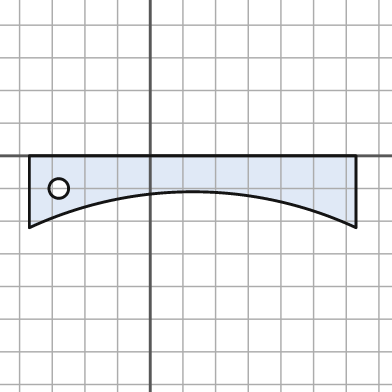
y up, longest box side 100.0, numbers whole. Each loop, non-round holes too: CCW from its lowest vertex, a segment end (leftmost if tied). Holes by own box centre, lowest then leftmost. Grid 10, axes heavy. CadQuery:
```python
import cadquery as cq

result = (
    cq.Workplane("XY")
    .moveTo(-37.0, -22.0)
    .threePointArc((13.0, -11.0), (63.0, -22.0))
    .lineTo(63.0, 0.0)
    .lineTo(-37.0, 0.0)
    .close()
    .moveTo(-28.0, -10.0)
    .circle(3.0)
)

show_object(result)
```